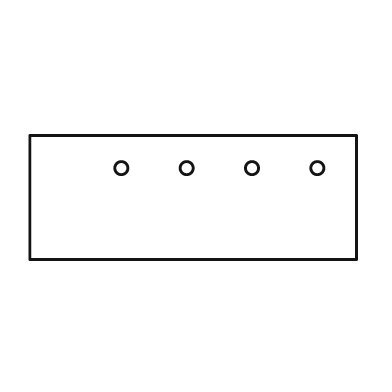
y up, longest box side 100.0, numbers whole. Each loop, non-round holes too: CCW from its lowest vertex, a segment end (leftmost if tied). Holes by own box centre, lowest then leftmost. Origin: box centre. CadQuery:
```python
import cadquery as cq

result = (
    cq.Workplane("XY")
    .moveTo(-50.0, -19.0)
    .lineTo(50.0, -19.0)
    .lineTo(50.0, 19.0)
    .lineTo(-50.0, 19.0)
    .close()
    .moveTo(-22.0, 9.0)
    .circle(2.0)
    .moveTo(-2.0, 9.0)
    .circle(2.0)
    .moveTo(18.0, 9.0)
    .circle(2.0)
    .moveTo(38.0, 9.0)
    .circle(2.0)
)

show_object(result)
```